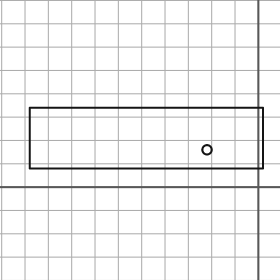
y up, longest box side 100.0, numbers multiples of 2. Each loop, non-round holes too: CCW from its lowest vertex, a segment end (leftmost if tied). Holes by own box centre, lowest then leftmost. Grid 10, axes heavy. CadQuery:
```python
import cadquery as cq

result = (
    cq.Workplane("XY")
    .moveTo(-98.0, 8.0)
    .lineTo(2.0, 8.0)
    .lineTo(2.0, 34.0)
    .lineTo(-98.0, 34.0)
    .close()
    .moveTo(-22.0, 16.0)
    .circle(2.0)
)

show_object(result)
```